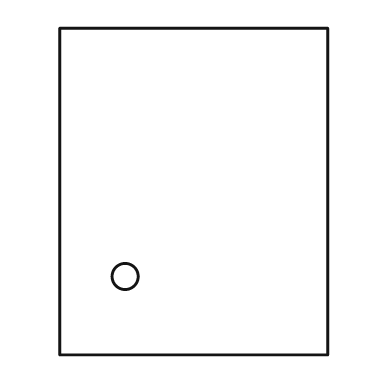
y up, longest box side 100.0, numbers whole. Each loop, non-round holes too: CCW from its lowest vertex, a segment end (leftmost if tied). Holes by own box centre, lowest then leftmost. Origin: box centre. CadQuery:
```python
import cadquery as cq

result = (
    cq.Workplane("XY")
    .moveTo(-41.0, -50.0)
    .lineTo(41.0, -50.0)
    .lineTo(41.0, 50.0)
    .lineTo(-41.0, 50.0)
    .close()
    .moveTo(-21.0, -26.0)
    .circle(4.0)
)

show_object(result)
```